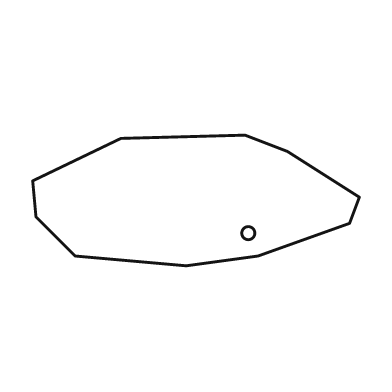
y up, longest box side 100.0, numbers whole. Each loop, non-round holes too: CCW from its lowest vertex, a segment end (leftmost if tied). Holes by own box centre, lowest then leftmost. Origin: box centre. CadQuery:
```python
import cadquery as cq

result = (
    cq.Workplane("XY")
    .moveTo(-3.0, -20.0)
    .lineTo(19.0, -17.0)
    .lineTo(47.0, -7.0)
    .lineTo(50.0, 1.0)
    .lineTo(28.0, 15.0)
    .lineTo(15.0, 20.0)
    .lineTo(-23.0, 19.0)
    .lineTo(-50.0, 6.0)
    .lineTo(-49.0, -5.0)
    .lineTo(-37.0, -17.0)
    .close()
    .moveTo(16.0, -10.0)
    .circle(2.0)
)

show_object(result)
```